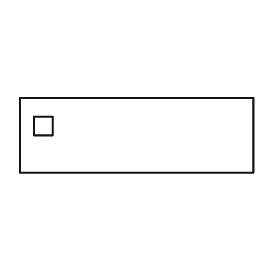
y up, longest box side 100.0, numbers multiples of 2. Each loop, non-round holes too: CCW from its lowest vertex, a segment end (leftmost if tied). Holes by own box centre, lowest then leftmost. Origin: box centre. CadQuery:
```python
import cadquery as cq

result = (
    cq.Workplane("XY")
    .moveTo(-50.0, -16.0)
    .lineTo(50.0, -16.0)
    .lineTo(50.0, 16.0)
    .lineTo(-50.0, 16.0)
    .close()
    .moveTo(-44.0, 0.0)
    .lineTo(-36.0, 0.0)
    .lineTo(-36.0, 8.0)
    .lineTo(-44.0, 8.0)
    .close()
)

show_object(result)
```